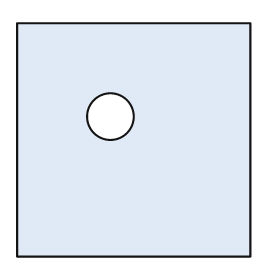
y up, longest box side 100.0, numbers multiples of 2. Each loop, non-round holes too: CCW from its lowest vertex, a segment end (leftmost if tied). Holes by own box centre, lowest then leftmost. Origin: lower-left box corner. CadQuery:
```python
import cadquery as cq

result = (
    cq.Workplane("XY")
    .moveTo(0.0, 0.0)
    .lineTo(100.0, 0.0)
    .lineTo(100.0, 100.0)
    .lineTo(0.0, 100.0)
    .close()
    .moveTo(40.0, 60.0)
    .circle(10.0)
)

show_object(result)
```